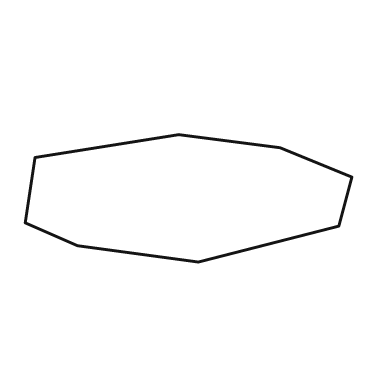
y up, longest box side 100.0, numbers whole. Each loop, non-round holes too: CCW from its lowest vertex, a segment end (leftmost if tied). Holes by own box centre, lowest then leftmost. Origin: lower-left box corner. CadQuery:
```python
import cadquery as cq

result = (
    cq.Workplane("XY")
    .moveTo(53.0, 0.0)
    .lineTo(96.0, 11.0)
    .lineTo(100.0, 26.0)
    .lineTo(78.0, 35.0)
    .lineTo(47.0, 39.0)
    .lineTo(3.0, 32.0)
    .lineTo(0.0, 12.0)
    .lineTo(16.0, 5.0)
    .close()
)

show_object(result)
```